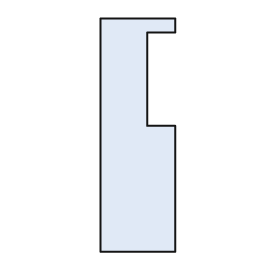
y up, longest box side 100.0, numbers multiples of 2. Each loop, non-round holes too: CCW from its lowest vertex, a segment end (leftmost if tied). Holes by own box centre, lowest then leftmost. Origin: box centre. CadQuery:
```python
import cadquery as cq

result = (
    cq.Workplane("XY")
    .moveTo(-16.0, -50.0)
    .lineTo(16.0, -50.0)
    .lineTo(16.0, 4.0)
    .lineTo(4.0, 4.0)
    .lineTo(4.0, 44.0)
    .lineTo(16.0, 44.0)
    .lineTo(16.0, 50.0)
    .lineTo(-16.0, 50.0)
    .close()
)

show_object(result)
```